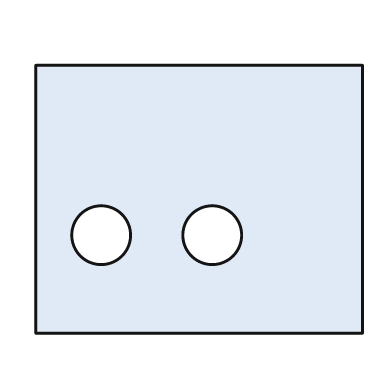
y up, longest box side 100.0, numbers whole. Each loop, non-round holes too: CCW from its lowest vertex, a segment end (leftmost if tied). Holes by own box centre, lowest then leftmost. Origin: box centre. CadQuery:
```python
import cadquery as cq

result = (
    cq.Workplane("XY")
    .moveTo(-50.0, -41.0)
    .lineTo(50.0, -41.0)
    .lineTo(50.0, 41.0)
    .lineTo(-50.0, 41.0)
    .close()
    .moveTo(-30.0, -11.0)
    .circle(9.0)
    .moveTo(4.0, -11.0)
    .circle(9.0)
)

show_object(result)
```